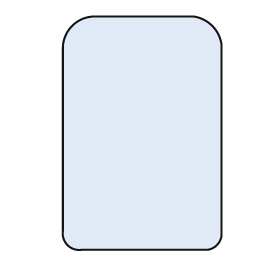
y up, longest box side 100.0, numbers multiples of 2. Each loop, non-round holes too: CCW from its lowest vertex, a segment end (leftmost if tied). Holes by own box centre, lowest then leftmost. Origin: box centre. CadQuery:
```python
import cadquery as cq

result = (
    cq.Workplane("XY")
    .moveTo(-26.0, -50.0)
    .lineTo(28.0, -50.0)
    .threePointArc((32.0, -48.0), (34.0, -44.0))
    .lineTo(34.0, 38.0)
    .threePointArc((30.0, 46.0), (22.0, 50.0))
    .lineTo(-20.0, 50.0)
    .threePointArc((-30.0, 46.0), (-34.0, 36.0))
    .lineTo(-34.0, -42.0)
    .threePointArc((-32.0, -48.0), (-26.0, -50.0))
    .close()
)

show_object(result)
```